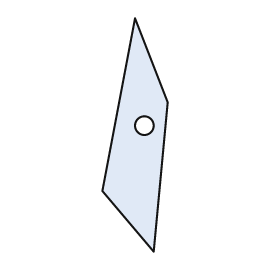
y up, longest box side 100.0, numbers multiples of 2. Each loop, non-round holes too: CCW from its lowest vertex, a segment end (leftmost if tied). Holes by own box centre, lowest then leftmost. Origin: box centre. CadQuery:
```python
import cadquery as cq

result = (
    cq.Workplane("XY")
    .moveTo(8.0, -50.0)
    .lineTo(14.0, 14.0)
    .lineTo(0.0, 50.0)
    .lineTo(-14.0, -24.0)
    .close()
    .moveTo(4.0, 4.0)
    .circle(4.0)
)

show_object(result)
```